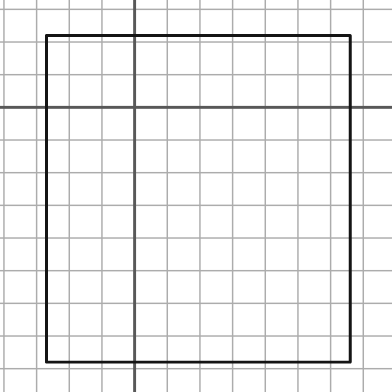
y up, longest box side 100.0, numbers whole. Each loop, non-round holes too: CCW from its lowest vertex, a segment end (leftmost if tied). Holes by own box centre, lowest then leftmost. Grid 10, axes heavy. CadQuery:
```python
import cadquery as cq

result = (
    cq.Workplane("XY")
    .moveTo(-27.0, -78.0)
    .lineTo(66.0, -78.0)
    .lineTo(66.0, 22.0)
    .lineTo(-27.0, 22.0)
    .close()
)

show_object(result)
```